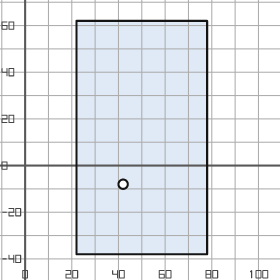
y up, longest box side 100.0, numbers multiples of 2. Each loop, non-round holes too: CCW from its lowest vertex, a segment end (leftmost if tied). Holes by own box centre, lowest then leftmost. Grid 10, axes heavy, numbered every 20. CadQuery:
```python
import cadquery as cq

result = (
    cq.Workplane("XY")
    .moveTo(22.0, -38.0)
    .lineTo(78.0, -38.0)
    .lineTo(78.0, 62.0)
    .lineTo(22.0, 62.0)
    .close()
    .moveTo(42.0, -8.0)
    .circle(2.0)
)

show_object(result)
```